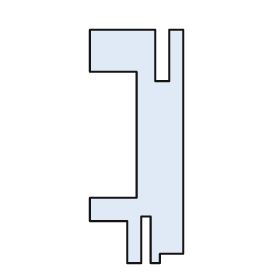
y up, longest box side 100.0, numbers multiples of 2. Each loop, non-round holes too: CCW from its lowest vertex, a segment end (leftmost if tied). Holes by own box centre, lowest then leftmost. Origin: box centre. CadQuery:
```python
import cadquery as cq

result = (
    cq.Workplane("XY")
    .moveTo(-4.0, -50.0)
    .lineTo(2.0, -50.0)
    .lineTo(2.0, -30.0)
    .lineTo(6.0, -30.0)
    .lineTo(6.0, -50.0)
    .lineTo(10.0, -50.0)
    .lineTo(10.0, -46.0)
    .lineTo(20.0, -46.0)
    .lineTo(20.0, 50.0)
    .lineTo(14.0, 50.0)
    .lineTo(14.0, 28.0)
    .lineTo(8.0, 28.0)
    .lineTo(8.0, 50.0)
    .lineTo(-20.0, 50.0)
    .lineTo(-20.0, 32.0)
    .lineTo(0.0, 32.0)
    .lineTo(0.0, -22.0)
    .lineTo(-20.0, -22.0)
    .lineTo(-20.0, -32.0)
    .lineTo(-4.0, -32.0)
    .close()
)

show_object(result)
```